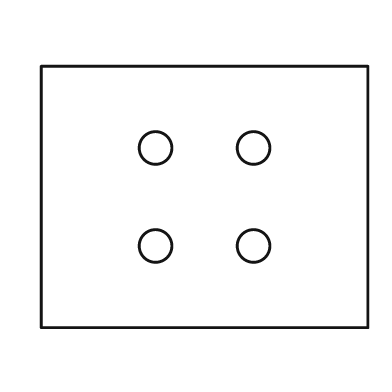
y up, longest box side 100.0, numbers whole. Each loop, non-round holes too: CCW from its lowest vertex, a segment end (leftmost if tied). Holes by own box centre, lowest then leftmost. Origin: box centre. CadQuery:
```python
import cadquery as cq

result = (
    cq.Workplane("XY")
    .moveTo(-50.0, -40.0)
    .lineTo(50.0, -40.0)
    .lineTo(50.0, 40.0)
    .lineTo(-50.0, 40.0)
    .close()
    .moveTo(-15.0, -15.0)
    .circle(5.0)
    .moveTo(15.0, -15.0)
    .circle(5.0)
    .moveTo(-15.0, 15.0)
    .circle(5.0)
    .moveTo(15.0, 15.0)
    .circle(5.0)
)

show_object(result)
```